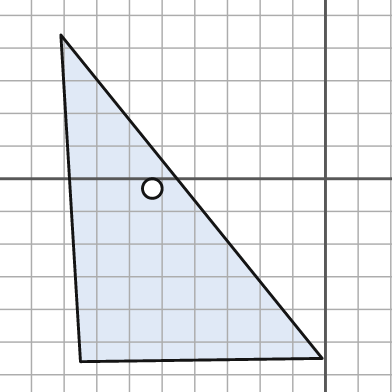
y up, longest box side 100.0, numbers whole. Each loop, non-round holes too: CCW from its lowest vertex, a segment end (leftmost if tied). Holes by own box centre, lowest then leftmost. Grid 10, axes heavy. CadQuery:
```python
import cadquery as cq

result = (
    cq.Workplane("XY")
    .moveTo(-75.0, -56.0)
    .lineTo(-1.0, -55.0)
    .lineTo(-81.0, 44.0)
    .close()
    .moveTo(-53.0, -3.0)
    .circle(3.0)
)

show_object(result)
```